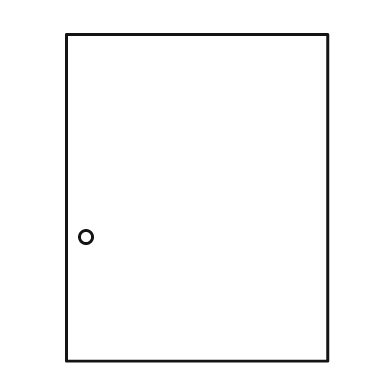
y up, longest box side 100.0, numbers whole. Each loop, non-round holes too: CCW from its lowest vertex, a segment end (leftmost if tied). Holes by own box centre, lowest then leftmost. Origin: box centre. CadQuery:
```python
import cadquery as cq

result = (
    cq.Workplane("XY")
    .moveTo(-40.0, -50.0)
    .lineTo(40.0, -50.0)
    .lineTo(40.0, 50.0)
    .lineTo(-40.0, 50.0)
    .close()
    .moveTo(-34.0, -12.0)
    .circle(2.0)
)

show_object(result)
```